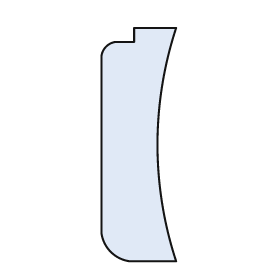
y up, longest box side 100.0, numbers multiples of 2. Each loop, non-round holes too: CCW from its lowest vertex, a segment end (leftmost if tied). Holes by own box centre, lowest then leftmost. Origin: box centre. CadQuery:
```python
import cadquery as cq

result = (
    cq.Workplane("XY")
    .moveTo(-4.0, -50.0)
    .lineTo(16.0, -50.0)
    .threePointArc((8.0, 0.0), (16.0, 50.0))
    .lineTo(-2.0, 50.0)
    .lineTo(-2.0, 44.0)
    .lineTo(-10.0, 44.0)
    .threePointArc((-14.0, 42.0), (-16.0, 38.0))
    .lineTo(-16.0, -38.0)
    .threePointArc((-12.0, -46.0), (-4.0, -50.0))
    .close()
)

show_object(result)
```